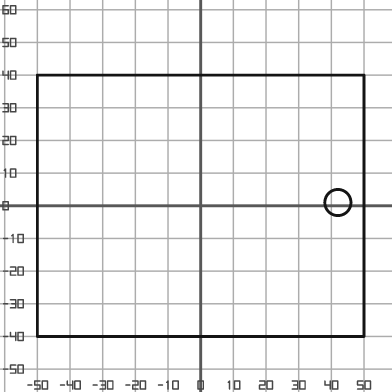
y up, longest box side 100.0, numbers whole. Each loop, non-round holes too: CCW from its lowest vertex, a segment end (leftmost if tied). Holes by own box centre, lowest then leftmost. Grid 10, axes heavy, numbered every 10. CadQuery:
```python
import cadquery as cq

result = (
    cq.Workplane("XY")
    .moveTo(-50.0, -40.0)
    .lineTo(50.0, -40.0)
    .lineTo(50.0, 40.0)
    .lineTo(-50.0, 40.0)
    .close()
    .moveTo(42.0, 1.0)
    .circle(4.0)
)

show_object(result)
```